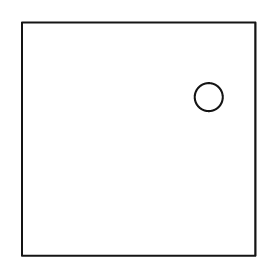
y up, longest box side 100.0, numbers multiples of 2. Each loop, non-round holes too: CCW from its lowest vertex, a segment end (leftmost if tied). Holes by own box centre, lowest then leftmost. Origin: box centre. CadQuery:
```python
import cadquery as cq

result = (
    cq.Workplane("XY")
    .moveTo(-50.0, -50.0)
    .lineTo(50.0, -50.0)
    .lineTo(50.0, 50.0)
    .lineTo(-50.0, 50.0)
    .close()
    .moveTo(30.0, 18.0)
    .circle(6.0)
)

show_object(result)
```